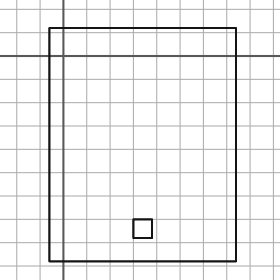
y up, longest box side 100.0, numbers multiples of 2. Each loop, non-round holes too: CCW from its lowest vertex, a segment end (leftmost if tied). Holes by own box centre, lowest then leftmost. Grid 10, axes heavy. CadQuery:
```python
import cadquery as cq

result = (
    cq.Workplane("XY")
    .moveTo(-6.0, -88.0)
    .lineTo(74.0, -88.0)
    .lineTo(74.0, 12.0)
    .lineTo(-6.0, 12.0)
    .close()
    .moveTo(30.0, -78.0)
    .lineTo(38.0, -78.0)
    .lineTo(38.0, -70.0)
    .lineTo(30.0, -70.0)
    .close()
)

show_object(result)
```